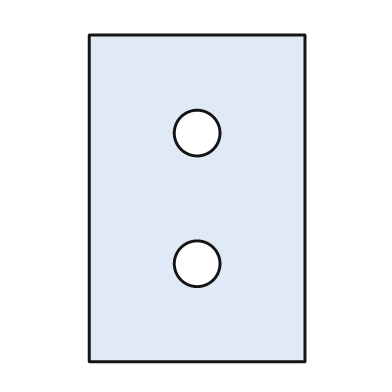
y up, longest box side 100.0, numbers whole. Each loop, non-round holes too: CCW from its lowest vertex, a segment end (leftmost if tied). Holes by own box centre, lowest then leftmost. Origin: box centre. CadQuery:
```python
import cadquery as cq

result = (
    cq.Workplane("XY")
    .moveTo(-33.0, -50.0)
    .lineTo(33.0, -50.0)
    .lineTo(33.0, 50.0)
    .lineTo(-33.0, 50.0)
    .close()
    .moveTo(0.0, -20.0)
    .circle(7.0)
    .moveTo(0.0, 20.0)
    .circle(7.0)
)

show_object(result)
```